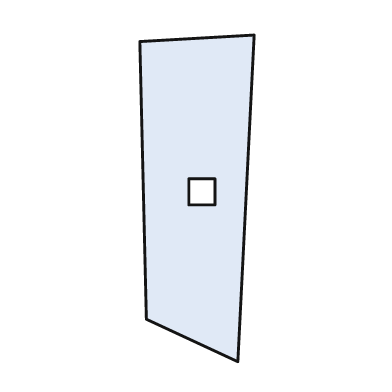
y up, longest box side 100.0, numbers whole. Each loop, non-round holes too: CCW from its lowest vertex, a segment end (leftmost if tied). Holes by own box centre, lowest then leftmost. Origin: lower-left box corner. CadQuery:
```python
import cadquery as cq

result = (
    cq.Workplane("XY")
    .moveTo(30.0, 0.0)
    .lineTo(35.0, 100.0)
    .lineTo(0.0, 98.0)
    .lineTo(2.0, 13.0)
    .close()
    .moveTo(15.0, 48.0)
    .lineTo(23.0, 48.0)
    .lineTo(23.0, 56.0)
    .lineTo(15.0, 56.0)
    .close()
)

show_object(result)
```